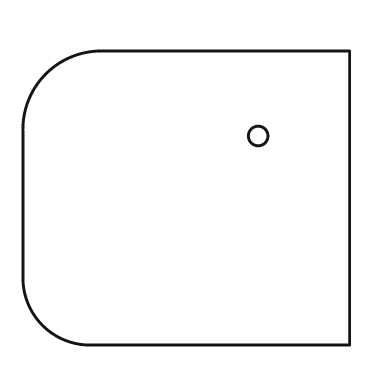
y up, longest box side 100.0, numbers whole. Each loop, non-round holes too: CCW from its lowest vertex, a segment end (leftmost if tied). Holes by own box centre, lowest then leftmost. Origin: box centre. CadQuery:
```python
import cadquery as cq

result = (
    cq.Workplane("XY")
    .moveTo(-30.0, -45.0)
    .lineTo(50.0, -45.0)
    .lineTo(50.0, 45.0)
    .lineTo(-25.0, 45.0)
    .threePointArc((-43.0, 38.0), (-50.0, 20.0))
    .lineTo(-50.0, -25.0)
    .threePointArc((-44.0, -39.0), (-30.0, -45.0))
    .close()
    .moveTo(22.0, 19.0)
    .circle(3.0)
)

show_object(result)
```